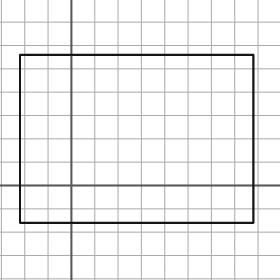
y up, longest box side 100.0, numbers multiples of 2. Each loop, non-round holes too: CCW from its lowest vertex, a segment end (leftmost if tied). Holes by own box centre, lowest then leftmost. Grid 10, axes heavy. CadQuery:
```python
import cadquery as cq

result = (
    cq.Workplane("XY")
    .moveTo(-22.0, -16.0)
    .lineTo(78.0, -16.0)
    .lineTo(78.0, 56.0)
    .lineTo(-22.0, 56.0)
    .close()
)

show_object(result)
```